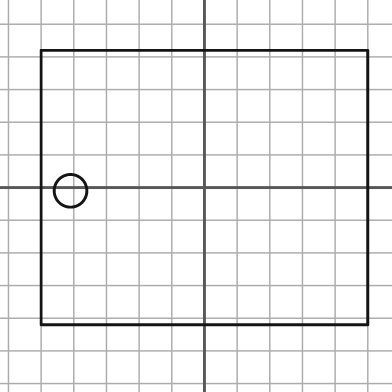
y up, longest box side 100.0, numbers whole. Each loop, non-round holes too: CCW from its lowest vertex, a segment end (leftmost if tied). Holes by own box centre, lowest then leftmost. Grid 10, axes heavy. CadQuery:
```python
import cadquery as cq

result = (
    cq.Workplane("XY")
    .moveTo(-50.0, -42.0)
    .lineTo(50.0, -42.0)
    .lineTo(50.0, 42.0)
    .lineTo(-50.0, 42.0)
    .close()
    .moveTo(-41.0, -1.0)
    .circle(5.0)
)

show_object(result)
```